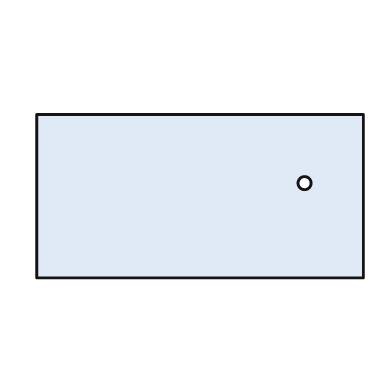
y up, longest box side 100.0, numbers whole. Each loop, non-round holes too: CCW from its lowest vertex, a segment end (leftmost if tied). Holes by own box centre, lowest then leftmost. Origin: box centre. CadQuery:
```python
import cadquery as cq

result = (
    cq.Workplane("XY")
    .moveTo(-50.0, -25.0)
    .lineTo(50.0, -25.0)
    .lineTo(50.0, 25.0)
    .lineTo(-50.0, 25.0)
    .close()
    .moveTo(32.0, 4.0)
    .circle(2.0)
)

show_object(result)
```